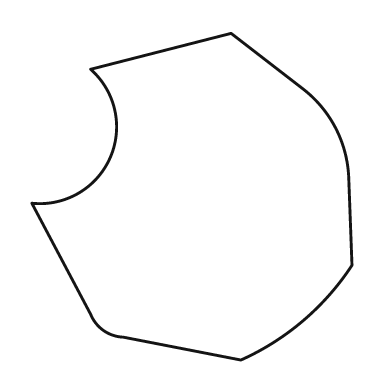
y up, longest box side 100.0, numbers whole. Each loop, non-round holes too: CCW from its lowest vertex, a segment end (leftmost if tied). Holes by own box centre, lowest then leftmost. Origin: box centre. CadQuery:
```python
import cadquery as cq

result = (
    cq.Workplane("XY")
    .moveTo(15.0, -50.0)
    .threePointArc((34.0, -38.0), (49.0, -21.0))
    .lineTo(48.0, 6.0)
    .threePointArc((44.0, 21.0), (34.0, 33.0))
    .lineTo(12.0, 50.0)
    .lineTo(-31.0, 39.0)
    .threePointArc((-25.0, 12.0), (-49.0, -2.0))
    .lineTo(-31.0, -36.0)
    .threePointArc((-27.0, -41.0), (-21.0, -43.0))
    .close()
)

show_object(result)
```